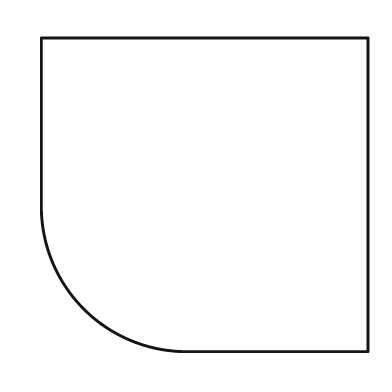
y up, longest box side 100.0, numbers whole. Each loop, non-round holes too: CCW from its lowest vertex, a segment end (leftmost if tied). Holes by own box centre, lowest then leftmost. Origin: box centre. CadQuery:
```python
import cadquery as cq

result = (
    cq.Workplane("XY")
    .moveTo(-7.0, -48.0)
    .lineTo(50.0, -48.0)
    .lineTo(50.0, 48.0)
    .lineTo(-50.0, 48.0)
    .lineTo(-50.0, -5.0)
    .threePointArc((-37.0, -35.0), (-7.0, -48.0))
    .close()
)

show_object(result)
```